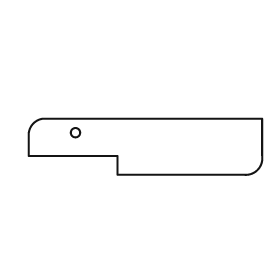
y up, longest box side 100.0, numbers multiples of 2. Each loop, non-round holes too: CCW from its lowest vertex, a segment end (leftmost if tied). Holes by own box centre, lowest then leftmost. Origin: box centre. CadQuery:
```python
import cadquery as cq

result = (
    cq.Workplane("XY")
    .moveTo(-12.0, -12.0)
    .lineTo(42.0, -12.0)
    .threePointArc((48.0, -10.0), (50.0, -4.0))
    .lineTo(50.0, 12.0)
    .lineTo(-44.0, 12.0)
    .threePointArc((-48.0, 10.0), (-50.0, 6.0))
    .lineTo(-50.0, -4.0)
    .lineTo(-12.0, -4.0)
    .close()
    .moveTo(-30.0, 6.0)
    .circle(2.0)
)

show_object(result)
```